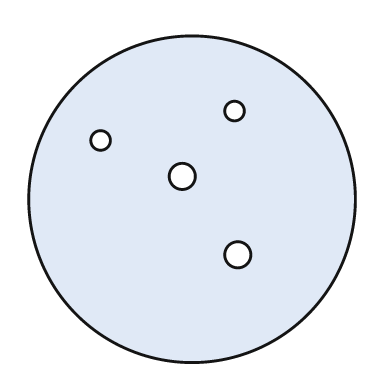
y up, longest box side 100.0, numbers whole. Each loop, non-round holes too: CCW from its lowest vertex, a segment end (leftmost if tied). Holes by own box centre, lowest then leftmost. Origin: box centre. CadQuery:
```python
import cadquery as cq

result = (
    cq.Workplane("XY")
    .moveTo(0.0, 0.0)
    .circle(50.0)
    .moveTo(14.0, -17.0)
    .circle(4.0)
    .moveTo(-3.0, 7.0)
    .circle(4.0)
    .moveTo(-28.0, 18.0)
    .circle(3.0)
    .moveTo(13.0, 27.0)
    .circle(3.0)
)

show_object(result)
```